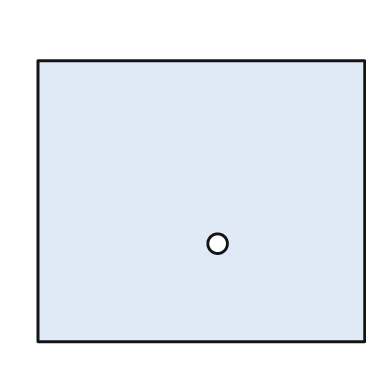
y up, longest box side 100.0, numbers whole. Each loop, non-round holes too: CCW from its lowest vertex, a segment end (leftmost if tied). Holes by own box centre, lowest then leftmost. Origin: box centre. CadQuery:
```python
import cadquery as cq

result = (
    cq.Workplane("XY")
    .moveTo(-50.0, -43.0)
    .lineTo(50.0, -43.0)
    .lineTo(50.0, 43.0)
    .lineTo(-50.0, 43.0)
    .close()
    .moveTo(5.0, -13.0)
    .circle(3.0)
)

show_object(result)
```